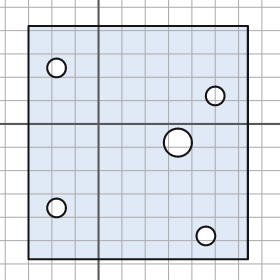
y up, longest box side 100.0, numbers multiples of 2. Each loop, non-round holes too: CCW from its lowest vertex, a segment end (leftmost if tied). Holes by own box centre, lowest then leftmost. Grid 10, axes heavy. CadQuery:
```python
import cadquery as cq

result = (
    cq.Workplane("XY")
    .moveTo(-30.0, -58.0)
    .lineTo(64.0, -58.0)
    .lineTo(64.0, 42.0)
    .lineTo(-30.0, 42.0)
    .close()
    .moveTo(46.0, -48.0)
    .circle(4.0)
    .moveTo(-18.0, -36.0)
    .circle(4.0)
    .moveTo(34.0, -8.0)
    .circle(6.0)
    .moveTo(50.0, 12.0)
    .circle(4.0)
    .moveTo(-18.0, 24.0)
    .circle(4.0)
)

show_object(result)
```